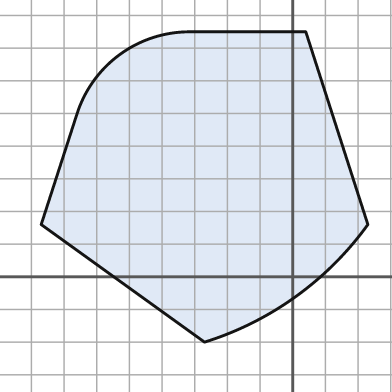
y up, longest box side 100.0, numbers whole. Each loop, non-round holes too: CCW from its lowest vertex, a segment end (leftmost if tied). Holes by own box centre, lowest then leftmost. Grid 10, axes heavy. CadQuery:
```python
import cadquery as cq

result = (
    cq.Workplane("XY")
    .moveTo(-27.0, -20.0)
    .threePointArc((1.0, -6.0), (23.0, 16.0))
    .lineTo(4.0, 75.0)
    .lineTo(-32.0, 75.0)
    .threePointArc((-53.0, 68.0), (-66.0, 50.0))
    .lineTo(-77.0, 16.0)
    .close()
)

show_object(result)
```